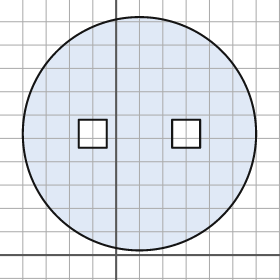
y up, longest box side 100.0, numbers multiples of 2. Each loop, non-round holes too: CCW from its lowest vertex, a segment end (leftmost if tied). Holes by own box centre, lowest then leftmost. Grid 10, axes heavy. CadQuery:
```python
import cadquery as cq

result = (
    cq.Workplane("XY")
    .moveTo(10.0, 52.0)
    .circle(50.0)
    .moveTo(-16.0, 46.0)
    .lineTo(-4.0, 46.0)
    .lineTo(-4.0, 58.0)
    .lineTo(-16.0, 58.0)
    .close()
    .moveTo(24.0, 46.0)
    .lineTo(36.0, 46.0)
    .lineTo(36.0, 58.0)
    .lineTo(24.0, 58.0)
    .close()
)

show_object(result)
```